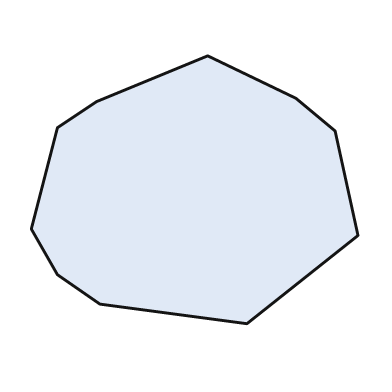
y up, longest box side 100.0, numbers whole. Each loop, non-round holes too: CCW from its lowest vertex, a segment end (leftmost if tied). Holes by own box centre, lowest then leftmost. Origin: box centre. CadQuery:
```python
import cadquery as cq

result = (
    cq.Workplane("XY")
    .moveTo(16.0, -41.0)
    .lineTo(50.0, -14.0)
    .lineTo(43.0, 18.0)
    .lineTo(31.0, 28.0)
    .lineTo(4.0, 41.0)
    .lineTo(-30.0, 27.0)
    .lineTo(-42.0, 19.0)
    .lineTo(-50.0, -12.0)
    .lineTo(-42.0, -26.0)
    .lineTo(-29.0, -35.0)
    .close()
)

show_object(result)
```